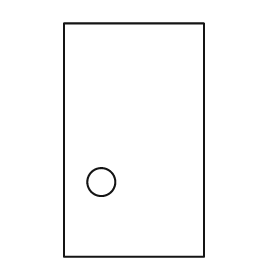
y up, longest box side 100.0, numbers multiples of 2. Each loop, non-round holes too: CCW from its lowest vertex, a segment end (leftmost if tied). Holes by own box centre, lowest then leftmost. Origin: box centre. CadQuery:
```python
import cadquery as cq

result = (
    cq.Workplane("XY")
    .moveTo(-30.0, -50.0)
    .lineTo(30.0, -50.0)
    .lineTo(30.0, 50.0)
    .lineTo(-30.0, 50.0)
    .close()
    .moveTo(-14.0, -18.0)
    .circle(6.0)
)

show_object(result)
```